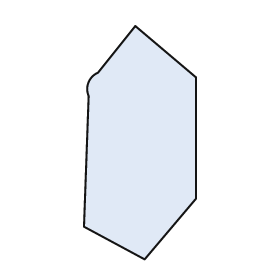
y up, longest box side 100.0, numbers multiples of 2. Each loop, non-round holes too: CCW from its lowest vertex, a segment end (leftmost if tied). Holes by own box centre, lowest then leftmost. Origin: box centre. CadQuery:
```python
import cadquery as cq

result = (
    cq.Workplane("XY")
    .moveTo(2.0, -50.0)
    .lineTo(24.0, -24.0)
    .lineTo(24.0, 28.0)
    .lineTo(-2.0, 50.0)
    .lineTo(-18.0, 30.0)
    .threePointArc((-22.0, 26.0), (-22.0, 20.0))
    .lineTo(-24.0, -36.0)
    .close()
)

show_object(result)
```